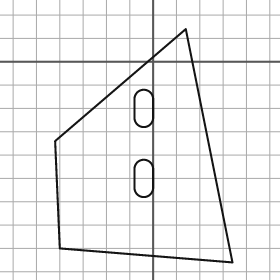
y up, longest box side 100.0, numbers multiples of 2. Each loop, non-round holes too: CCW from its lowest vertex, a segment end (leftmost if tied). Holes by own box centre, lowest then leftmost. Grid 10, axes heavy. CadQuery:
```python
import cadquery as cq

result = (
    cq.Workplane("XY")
    .moveTo(34.0, -86.0)
    .lineTo(14.0, 14.0)
    .lineTo(-42.0, -34.0)
    .lineTo(-40.0, -80.0)
    .close()
    .moveTo(-8.0, -54.0)
    .threePointArc((-4.0, -58.0), (0.0, -54.0))
    .lineTo(0.0, -46.0)
    .threePointArc((-4.0, -42.0), (-8.0, -46.0))
    .close()
    .moveTo(-8.0, -24.0)
    .threePointArc((-4.0, -28.0), (0.0, -24.0))
    .lineTo(0.0, -16.0)
    .threePointArc((-4.0, -12.0), (-8.0, -16.0))
    .close()
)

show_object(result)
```